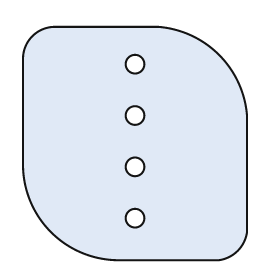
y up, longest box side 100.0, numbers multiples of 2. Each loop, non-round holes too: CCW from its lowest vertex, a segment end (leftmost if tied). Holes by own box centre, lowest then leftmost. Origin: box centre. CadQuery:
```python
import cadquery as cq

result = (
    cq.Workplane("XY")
    .moveTo(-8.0, -50.0)
    .lineTo(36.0, -50.0)
    .threePointArc((44.0, -46.0), (48.0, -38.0))
    .lineTo(48.0, 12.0)
    .threePointArc((36.0, 38.0), (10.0, 50.0))
    .lineTo(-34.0, 50.0)
    .threePointArc((-44.0, 46.0), (-48.0, 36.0))
    .lineTo(-48.0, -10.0)
    .threePointArc((-36.0, -38.0), (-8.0, -50.0))
    .close()
    .moveTo(0.0, -32.0)
    .circle(4.0)
    .moveTo(0.0, -10.0)
    .circle(4.0)
    .moveTo(0.0, 12.0)
    .circle(4.0)
    .moveTo(0.0, 34.0)
    .circle(4.0)
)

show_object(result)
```